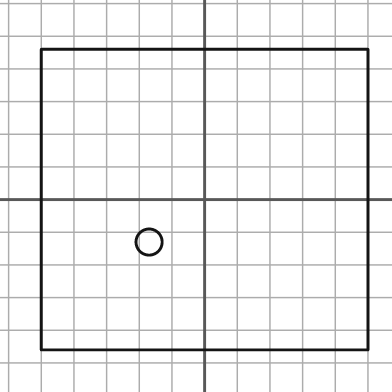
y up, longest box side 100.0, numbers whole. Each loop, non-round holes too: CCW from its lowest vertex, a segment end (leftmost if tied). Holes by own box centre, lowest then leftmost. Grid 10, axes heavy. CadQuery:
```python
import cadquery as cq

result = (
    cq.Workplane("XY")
    .moveTo(-50.0, -46.0)
    .lineTo(50.0, -46.0)
    .lineTo(50.0, 46.0)
    .lineTo(-50.0, 46.0)
    .close()
    .moveTo(-17.0, -13.0)
    .circle(4.0)
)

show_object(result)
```